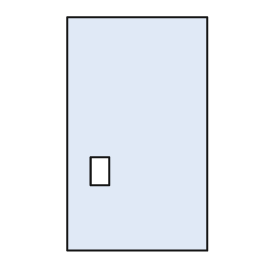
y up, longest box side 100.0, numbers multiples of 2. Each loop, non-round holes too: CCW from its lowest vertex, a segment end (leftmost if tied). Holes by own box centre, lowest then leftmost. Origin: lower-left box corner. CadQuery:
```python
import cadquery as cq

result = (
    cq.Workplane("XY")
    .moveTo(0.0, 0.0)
    .lineTo(60.0, 0.0)
    .lineTo(60.0, 100.0)
    .lineTo(0.0, 100.0)
    .close()
    .moveTo(10.0, 28.0)
    .lineTo(18.0, 28.0)
    .lineTo(18.0, 40.0)
    .lineTo(10.0, 40.0)
    .close()
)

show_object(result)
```